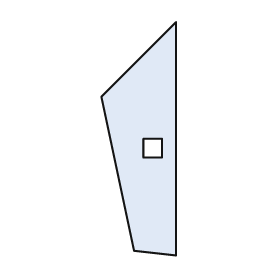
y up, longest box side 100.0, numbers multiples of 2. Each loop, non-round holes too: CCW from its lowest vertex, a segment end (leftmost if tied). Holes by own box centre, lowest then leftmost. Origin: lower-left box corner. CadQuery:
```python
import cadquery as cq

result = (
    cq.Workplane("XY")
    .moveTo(32.0, 0.0)
    .lineTo(32.0, 100.0)
    .lineTo(0.0, 68.0)
    .lineTo(14.0, 2.0)
    .close()
    .moveTo(18.0, 42.0)
    .lineTo(26.0, 42.0)
    .lineTo(26.0, 50.0)
    .lineTo(18.0, 50.0)
    .close()
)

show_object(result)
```